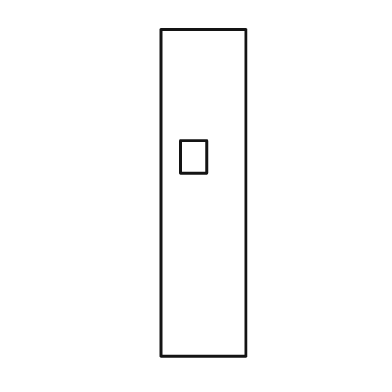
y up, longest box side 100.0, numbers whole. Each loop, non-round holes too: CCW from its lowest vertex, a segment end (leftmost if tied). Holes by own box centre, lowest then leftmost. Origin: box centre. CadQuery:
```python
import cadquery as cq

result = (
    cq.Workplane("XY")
    .moveTo(-13.0, -50.0)
    .lineTo(13.0, -50.0)
    .lineTo(13.0, 50.0)
    .lineTo(-13.0, 50.0)
    .close()
    .moveTo(-7.0, 6.0)
    .lineTo(1.0, 6.0)
    .lineTo(1.0, 16.0)
    .lineTo(-7.0, 16.0)
    .close()
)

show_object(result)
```